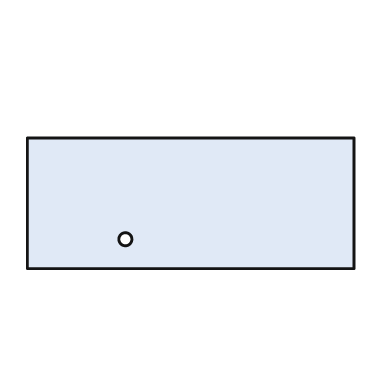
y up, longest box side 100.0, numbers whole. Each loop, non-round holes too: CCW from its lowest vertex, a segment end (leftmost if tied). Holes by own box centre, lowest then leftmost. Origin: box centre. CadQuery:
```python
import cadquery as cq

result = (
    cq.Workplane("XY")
    .moveTo(-50.0, -20.0)
    .lineTo(50.0, -20.0)
    .lineTo(50.0, 20.0)
    .lineTo(-50.0, 20.0)
    .close()
    .moveTo(-20.0, -11.0)
    .circle(2.0)
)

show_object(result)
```